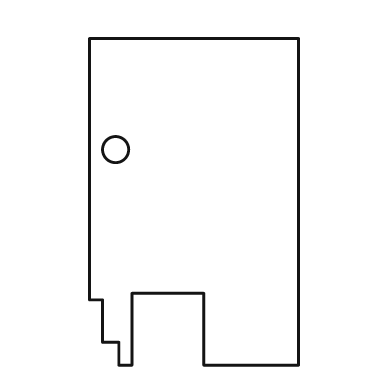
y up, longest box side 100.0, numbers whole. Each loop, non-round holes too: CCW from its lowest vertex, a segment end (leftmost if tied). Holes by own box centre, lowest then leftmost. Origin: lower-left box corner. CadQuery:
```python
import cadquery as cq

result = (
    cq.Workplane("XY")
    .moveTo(9.0, 0.0)
    .lineTo(13.0, 0.0)
    .lineTo(13.0, 22.0)
    .lineTo(35.0, 22.0)
    .lineTo(35.0, 0.0)
    .lineTo(64.0, 0.0)
    .lineTo(64.0, 100.0)
    .lineTo(0.0, 100.0)
    .lineTo(0.0, 20.0)
    .lineTo(4.0, 20.0)
    .lineTo(4.0, 7.0)
    .lineTo(9.0, 7.0)
    .close()
    .moveTo(8.0, 66.0)
    .circle(4.0)
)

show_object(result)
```